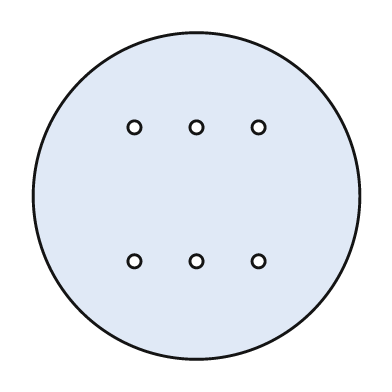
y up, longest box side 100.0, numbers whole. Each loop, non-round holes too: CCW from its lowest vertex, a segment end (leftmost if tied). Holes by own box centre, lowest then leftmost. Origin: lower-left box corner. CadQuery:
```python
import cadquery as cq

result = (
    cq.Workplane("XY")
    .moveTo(50.0, 50.0)
    .circle(50.0)
    .moveTo(31.0, 30.0)
    .circle(2.0)
    .moveTo(50.0, 30.0)
    .circle(2.0)
    .moveTo(69.0, 30.0)
    .circle(2.0)
    .moveTo(31.0, 71.0)
    .circle(2.0)
    .moveTo(50.0, 71.0)
    .circle(2.0)
    .moveTo(69.0, 71.0)
    .circle(2.0)
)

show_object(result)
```